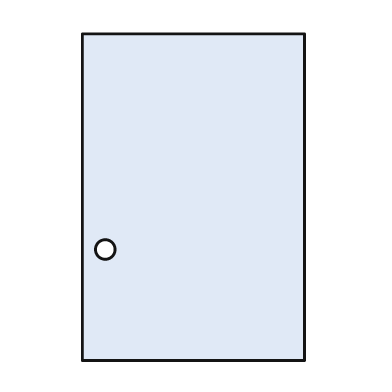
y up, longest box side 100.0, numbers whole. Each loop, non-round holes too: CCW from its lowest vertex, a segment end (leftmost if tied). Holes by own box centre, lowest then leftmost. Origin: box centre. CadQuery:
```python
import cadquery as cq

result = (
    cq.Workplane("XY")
    .moveTo(-34.0, -50.0)
    .lineTo(34.0, -50.0)
    .lineTo(34.0, 50.0)
    .lineTo(-34.0, 50.0)
    .close()
    .moveTo(-27.0, -16.0)
    .circle(3.0)
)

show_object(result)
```